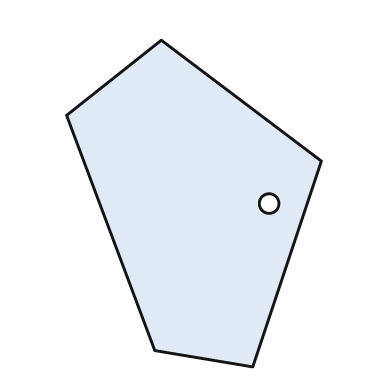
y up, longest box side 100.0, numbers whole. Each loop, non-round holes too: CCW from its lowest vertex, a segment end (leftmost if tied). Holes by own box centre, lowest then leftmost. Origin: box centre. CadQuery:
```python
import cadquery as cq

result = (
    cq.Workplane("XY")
    .moveTo(18.0, -50.0)
    .lineTo(39.0, 13.0)
    .lineTo(-10.0, 50.0)
    .lineTo(-39.0, 27.0)
    .lineTo(-12.0, -45.0)
    .close()
    .moveTo(23.0, 0.0)
    .circle(3.0)
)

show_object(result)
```